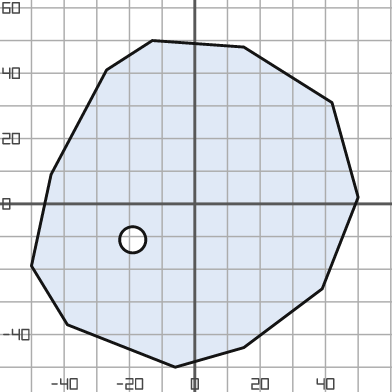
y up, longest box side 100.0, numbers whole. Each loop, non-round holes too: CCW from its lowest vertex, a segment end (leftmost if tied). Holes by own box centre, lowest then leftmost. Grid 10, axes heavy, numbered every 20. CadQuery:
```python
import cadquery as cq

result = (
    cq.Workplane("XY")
    .moveTo(-6.0, -50.0)
    .lineTo(15.0, -44.0)
    .lineTo(39.0, -26.0)
    .lineTo(50.0, 2.0)
    .lineTo(42.0, 31.0)
    .lineTo(15.0, 48.0)
    .lineTo(-13.0, 50.0)
    .lineTo(-27.0, 41.0)
    .lineTo(-44.0, 9.0)
    .lineTo(-50.0, -19.0)
    .lineTo(-39.0, -37.0)
    .close()
    .moveTo(-19.0, -11.0)
    .circle(4.0)
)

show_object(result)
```